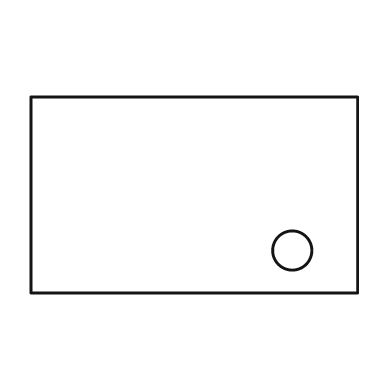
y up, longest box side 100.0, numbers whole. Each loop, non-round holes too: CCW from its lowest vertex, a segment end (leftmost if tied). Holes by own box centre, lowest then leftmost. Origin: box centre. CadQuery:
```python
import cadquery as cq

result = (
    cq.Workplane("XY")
    .moveTo(-50.0, -30.0)
    .lineTo(50.0, -30.0)
    .lineTo(50.0, 30.0)
    .lineTo(-50.0, 30.0)
    .close()
    .moveTo(30.0, -17.0)
    .circle(6.0)
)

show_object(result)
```